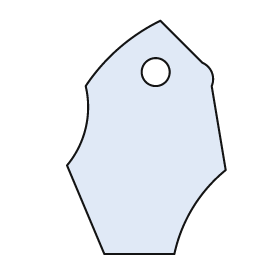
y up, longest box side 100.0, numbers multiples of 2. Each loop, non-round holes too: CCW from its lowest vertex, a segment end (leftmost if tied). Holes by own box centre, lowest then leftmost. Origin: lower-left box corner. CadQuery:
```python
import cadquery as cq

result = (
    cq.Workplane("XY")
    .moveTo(16.0, 0.0)
    .lineTo(46.0, 0.0)
    .threePointArc((54.0, 20.0), (68.0, 36.0))
    .lineTo(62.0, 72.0)
    .threePointArc((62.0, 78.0), (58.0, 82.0))
    .lineTo(40.0, 100.0)
    .threePointArc((22.0, 88.0), (8.0, 72.0))
    .threePointArc((8.0, 54.0), (0.0, 38.0))
    .close()
    .moveTo(38.0, 78.0)
    .circle(6.0)
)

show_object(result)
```